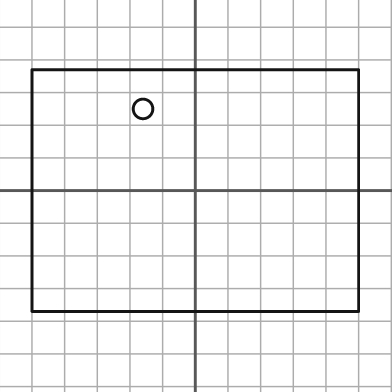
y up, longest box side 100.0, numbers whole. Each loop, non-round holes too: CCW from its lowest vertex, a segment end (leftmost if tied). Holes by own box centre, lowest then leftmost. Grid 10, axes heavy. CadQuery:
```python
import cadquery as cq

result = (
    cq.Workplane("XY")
    .moveTo(-50.0, -37.0)
    .lineTo(50.0, -37.0)
    .lineTo(50.0, 37.0)
    .lineTo(-50.0, 37.0)
    .close()
    .moveTo(-16.0, 25.0)
    .circle(3.0)
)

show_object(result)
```